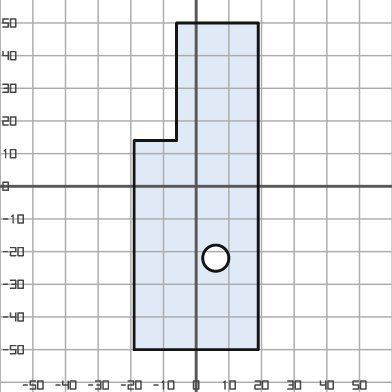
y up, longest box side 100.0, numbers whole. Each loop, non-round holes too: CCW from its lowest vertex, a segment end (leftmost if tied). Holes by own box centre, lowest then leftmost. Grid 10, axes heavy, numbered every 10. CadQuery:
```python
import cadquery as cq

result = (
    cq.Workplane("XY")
    .moveTo(-19.0, -50.0)
    .lineTo(19.0, -50.0)
    .lineTo(19.0, 50.0)
    .lineTo(-6.0, 50.0)
    .lineTo(-6.0, 14.0)
    .lineTo(-19.0, 14.0)
    .close()
    .moveTo(6.0, -22.0)
    .circle(4.0)
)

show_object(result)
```